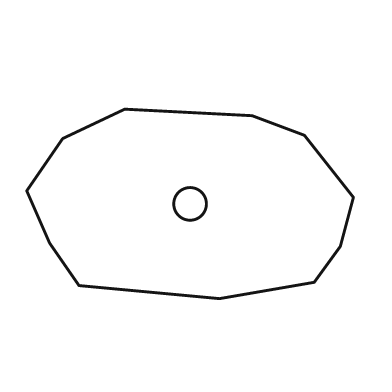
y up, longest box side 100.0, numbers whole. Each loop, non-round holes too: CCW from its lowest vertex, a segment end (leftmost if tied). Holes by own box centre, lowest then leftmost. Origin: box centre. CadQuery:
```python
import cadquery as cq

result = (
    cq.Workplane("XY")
    .moveTo(9.0, -29.0)
    .lineTo(38.0, -24.0)
    .lineTo(46.0, -13.0)
    .lineTo(50.0, 2.0)
    .lineTo(35.0, 21.0)
    .lineTo(19.0, 27.0)
    .lineTo(-20.0, 29.0)
    .lineTo(-39.0, 20.0)
    .lineTo(-50.0, 4.0)
    .lineTo(-43.0, -12.0)
    .lineTo(-34.0, -25.0)
    .close()
    .moveTo(0.0, 0.0)
    .circle(5.0)
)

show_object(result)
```